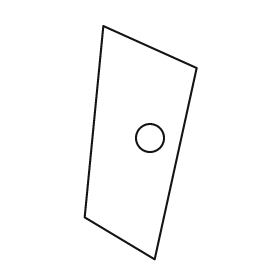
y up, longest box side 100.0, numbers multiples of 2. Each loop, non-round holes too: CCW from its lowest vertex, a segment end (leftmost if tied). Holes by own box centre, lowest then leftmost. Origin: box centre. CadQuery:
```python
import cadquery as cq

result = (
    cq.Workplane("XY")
    .moveTo(6.0, -50.0)
    .lineTo(24.0, 32.0)
    .lineTo(-16.0, 50.0)
    .lineTo(-24.0, -32.0)
    .close()
    .moveTo(4.0, 2.0)
    .circle(6.0)
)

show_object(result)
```